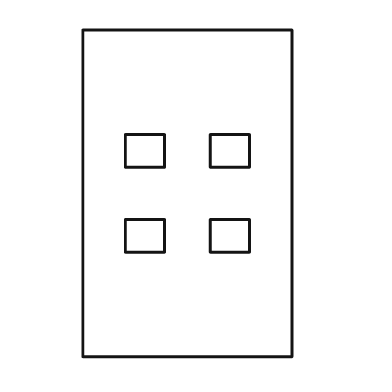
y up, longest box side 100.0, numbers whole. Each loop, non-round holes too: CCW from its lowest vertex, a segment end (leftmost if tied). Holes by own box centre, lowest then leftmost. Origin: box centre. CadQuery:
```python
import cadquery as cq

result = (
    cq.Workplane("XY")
    .moveTo(-32.0, -50.0)
    .lineTo(32.0, -50.0)
    .lineTo(32.0, 50.0)
    .lineTo(-32.0, 50.0)
    .close()
    .moveTo(-19.0, -18.0)
    .lineTo(-7.0, -18.0)
    .lineTo(-7.0, -8.0)
    .lineTo(-19.0, -8.0)
    .close()
    .moveTo(7.0, -18.0)
    .lineTo(19.0, -18.0)
    .lineTo(19.0, -8.0)
    .lineTo(7.0, -8.0)
    .close()
    .moveTo(-19.0, 8.0)
    .lineTo(-7.0, 8.0)
    .lineTo(-7.0, 18.0)
    .lineTo(-19.0, 18.0)
    .close()
    .moveTo(7.0, 8.0)
    .lineTo(19.0, 8.0)
    .lineTo(19.0, 18.0)
    .lineTo(7.0, 18.0)
    .close()
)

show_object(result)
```